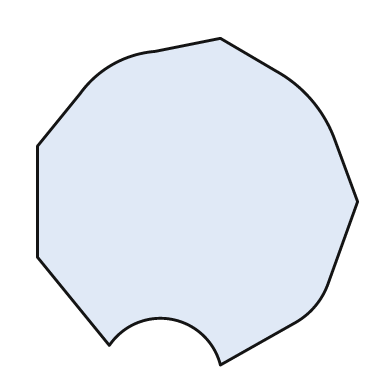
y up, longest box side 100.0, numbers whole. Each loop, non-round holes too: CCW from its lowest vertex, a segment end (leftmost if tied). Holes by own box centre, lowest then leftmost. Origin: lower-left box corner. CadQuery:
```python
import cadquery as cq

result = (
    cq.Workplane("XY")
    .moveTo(56.0, 0.0)
    .lineTo(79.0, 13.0)
    .threePointArc((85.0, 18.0), (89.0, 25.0))
    .lineTo(98.0, 50.0)
    .lineTo(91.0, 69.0)
    .threePointArc((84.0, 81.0), (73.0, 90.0))
    .lineTo(56.0, 100.0)
    .lineTo(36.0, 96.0)
    .threePointArc((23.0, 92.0), (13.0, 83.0))
    .lineTo(0.0, 67.0)
    .lineTo(0.0, 33.0)
    .lineTo(22.0, 6.0)
    .threePointArc((41.0, 14.0), (56.0, 0.0))
    .close()
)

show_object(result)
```